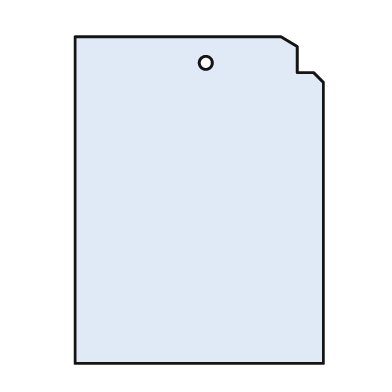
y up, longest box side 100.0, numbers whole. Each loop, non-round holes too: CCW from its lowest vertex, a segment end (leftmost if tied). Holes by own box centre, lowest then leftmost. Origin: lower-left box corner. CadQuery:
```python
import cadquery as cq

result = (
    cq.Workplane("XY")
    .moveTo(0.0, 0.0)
    .lineTo(76.0, 0.0)
    .lineTo(76.0, 86.0)
    .lineTo(73.0, 89.0)
    .lineTo(68.0, 89.0)
    .lineTo(68.0, 97.0)
    .lineTo(63.0, 100.0)
    .lineTo(0.0, 100.0)
    .close()
    .moveTo(40.0, 92.0)
    .circle(2.0)
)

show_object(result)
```